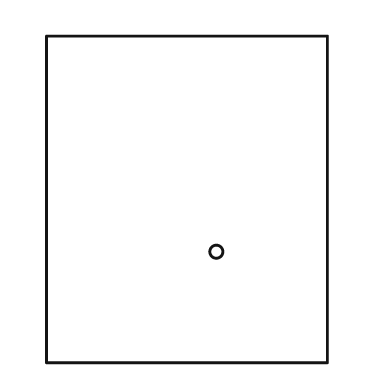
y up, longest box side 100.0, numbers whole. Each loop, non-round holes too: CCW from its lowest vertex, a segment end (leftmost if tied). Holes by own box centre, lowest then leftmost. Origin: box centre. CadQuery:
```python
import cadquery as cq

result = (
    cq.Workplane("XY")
    .moveTo(-43.0, -50.0)
    .lineTo(43.0, -50.0)
    .lineTo(43.0, 50.0)
    .lineTo(-43.0, 50.0)
    .close()
    .moveTo(9.0, -16.0)
    .circle(2.0)
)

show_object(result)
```